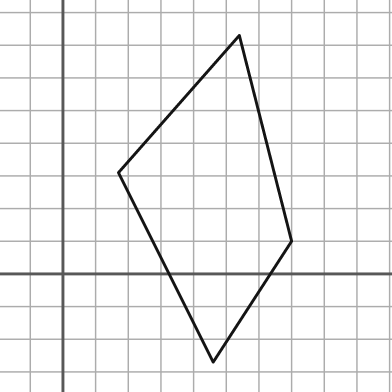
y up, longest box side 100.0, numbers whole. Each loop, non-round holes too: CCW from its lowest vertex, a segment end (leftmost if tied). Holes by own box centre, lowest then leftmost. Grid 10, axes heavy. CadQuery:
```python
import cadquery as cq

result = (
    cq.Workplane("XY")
    .moveTo(46.0, -27.0)
    .lineTo(70.0, 10.0)
    .lineTo(54.0, 73.0)
    .lineTo(17.0, 31.0)
    .close()
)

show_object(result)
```